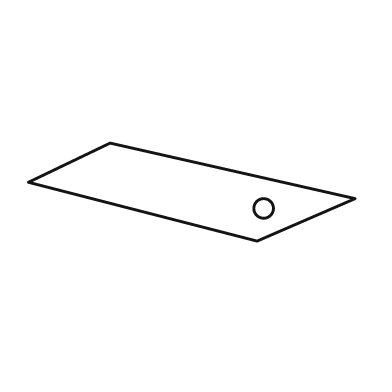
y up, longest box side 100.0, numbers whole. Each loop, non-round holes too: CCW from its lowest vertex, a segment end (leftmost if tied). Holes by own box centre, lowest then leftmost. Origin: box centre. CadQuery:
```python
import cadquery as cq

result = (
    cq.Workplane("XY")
    .moveTo(20.0, -15.0)
    .lineTo(50.0, -2.0)
    .lineTo(-25.0, 15.0)
    .lineTo(-50.0, 3.0)
    .close()
    .moveTo(22.0, -5.0)
    .circle(3.0)
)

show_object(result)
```